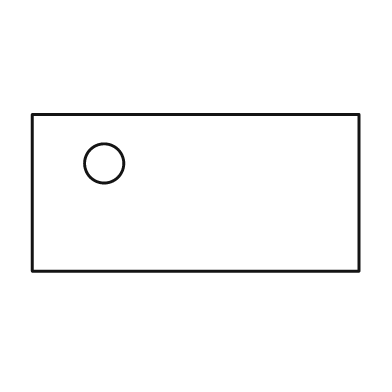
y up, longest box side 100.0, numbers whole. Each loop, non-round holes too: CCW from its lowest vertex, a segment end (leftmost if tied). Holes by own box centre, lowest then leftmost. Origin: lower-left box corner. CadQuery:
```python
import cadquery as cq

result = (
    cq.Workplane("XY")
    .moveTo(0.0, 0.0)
    .lineTo(100.0, 0.0)
    .lineTo(100.0, 48.0)
    .lineTo(0.0, 48.0)
    .close()
    .moveTo(22.0, 33.0)
    .circle(6.0)
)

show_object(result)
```